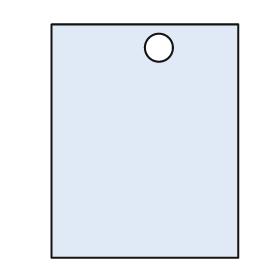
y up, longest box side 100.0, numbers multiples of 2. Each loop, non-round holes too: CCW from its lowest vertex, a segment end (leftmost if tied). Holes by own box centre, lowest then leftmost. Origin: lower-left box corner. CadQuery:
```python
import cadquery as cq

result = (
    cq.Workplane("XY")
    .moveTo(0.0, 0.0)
    .lineTo(80.0, 0.0)
    .lineTo(80.0, 100.0)
    .lineTo(0.0, 100.0)
    .close()
    .moveTo(46.0, 90.0)
    .circle(6.0)
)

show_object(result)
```